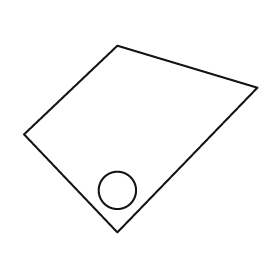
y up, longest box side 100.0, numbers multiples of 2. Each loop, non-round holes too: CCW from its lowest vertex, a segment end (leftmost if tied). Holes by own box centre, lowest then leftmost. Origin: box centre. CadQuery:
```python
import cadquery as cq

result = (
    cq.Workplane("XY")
    .moveTo(-10.0, -40.0)
    .lineTo(50.0, 22.0)
    .lineTo(-10.0, 40.0)
    .lineTo(-50.0, 2.0)
    .close()
    .moveTo(-10.0, -22.0)
    .circle(8.0)
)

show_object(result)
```